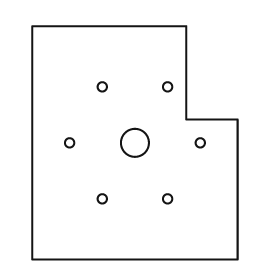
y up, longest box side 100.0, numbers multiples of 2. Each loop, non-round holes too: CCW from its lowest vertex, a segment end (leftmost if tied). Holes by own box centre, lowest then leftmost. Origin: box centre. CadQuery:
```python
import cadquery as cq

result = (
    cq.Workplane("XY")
    .moveTo(-44.0, -50.0)
    .lineTo(44.0, -50.0)
    .lineTo(44.0, 10.0)
    .lineTo(22.0, 10.0)
    .lineTo(22.0, 50.0)
    .lineTo(-44.0, 50.0)
    .close()
    .moveTo(-14.0, -24.0)
    .circle(2.0)
    .moveTo(14.0, -24.0)
    .circle(2.0)
    .moveTo(-28.0, 0.0)
    .circle(2.0)
    .moveTo(0.0, 0.0)
    .circle(6.0)
    .moveTo(28.0, 0.0)
    .circle(2.0)
    .moveTo(-14.0, 24.0)
    .circle(2.0)
    .moveTo(14.0, 24.0)
    .circle(2.0)
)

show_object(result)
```